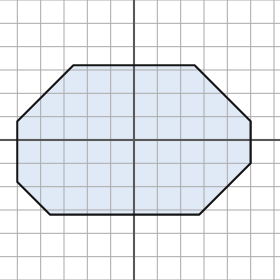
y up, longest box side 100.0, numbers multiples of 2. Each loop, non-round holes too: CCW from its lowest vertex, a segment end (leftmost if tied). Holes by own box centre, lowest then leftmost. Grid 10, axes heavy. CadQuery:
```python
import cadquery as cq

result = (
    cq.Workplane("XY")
    .moveTo(-36.0, -32.0)
    .lineTo(28.0, -32.0)
    .lineTo(50.0, -10.0)
    .lineTo(50.0, 8.0)
    .lineTo(26.0, 32.0)
    .lineTo(-26.0, 32.0)
    .lineTo(-50.0, 8.0)
    .lineTo(-50.0, -18.0)
    .close()
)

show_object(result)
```